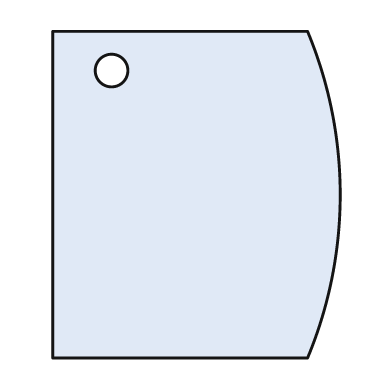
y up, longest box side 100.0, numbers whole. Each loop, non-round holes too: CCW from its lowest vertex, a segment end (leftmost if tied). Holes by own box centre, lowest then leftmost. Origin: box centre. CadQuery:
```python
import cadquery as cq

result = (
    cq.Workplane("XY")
    .moveTo(-44.0, -50.0)
    .lineTo(34.0, -50.0)
    .threePointArc((44.0, 0.0), (34.0, 50.0))
    .lineTo(-44.0, 50.0)
    .close()
    .moveTo(-26.0, 38.0)
    .circle(5.0)
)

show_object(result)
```